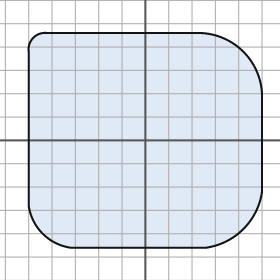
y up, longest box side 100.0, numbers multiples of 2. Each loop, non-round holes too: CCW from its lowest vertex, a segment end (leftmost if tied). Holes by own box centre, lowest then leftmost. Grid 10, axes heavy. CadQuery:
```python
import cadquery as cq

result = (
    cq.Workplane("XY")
    .moveTo(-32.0, -46.0)
    .lineTo(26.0, -46.0)
    .threePointArc((42.0, -38.0), (50.0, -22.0))
    .lineTo(50.0, 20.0)
    .threePointArc((42.0, 38.0), (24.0, 46.0))
    .lineTo(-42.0, 46.0)
    .threePointArc((-48.0, 44.0), (-50.0, 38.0))
    .lineTo(-50.0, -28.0)
    .threePointArc((-44.0, -40.0), (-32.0, -46.0))
    .close()
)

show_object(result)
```